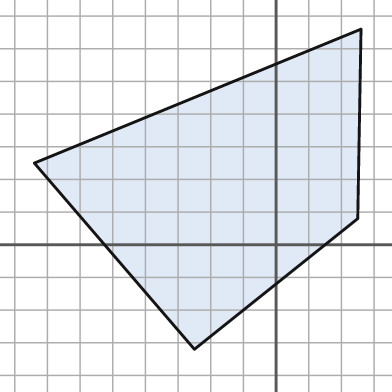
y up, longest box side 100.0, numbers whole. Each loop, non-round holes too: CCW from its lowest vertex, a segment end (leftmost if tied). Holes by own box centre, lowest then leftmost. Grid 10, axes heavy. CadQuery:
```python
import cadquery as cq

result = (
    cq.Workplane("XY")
    .moveTo(-25.0, -32.0)
    .lineTo(25.0, 8.0)
    .lineTo(26.0, 66.0)
    .lineTo(-74.0, 25.0)
    .close()
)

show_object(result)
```